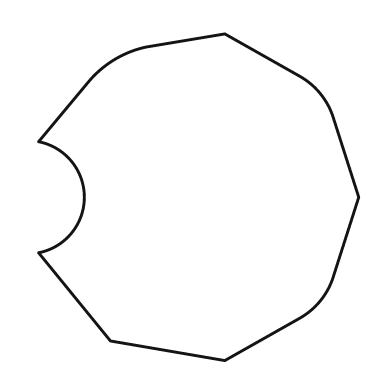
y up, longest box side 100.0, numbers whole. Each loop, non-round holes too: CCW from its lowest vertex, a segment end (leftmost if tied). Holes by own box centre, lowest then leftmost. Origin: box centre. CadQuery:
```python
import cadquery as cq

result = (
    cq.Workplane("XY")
    .moveTo(8.0, -50.0)
    .lineTo(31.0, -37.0)
    .threePointArc((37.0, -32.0), (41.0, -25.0))
    .lineTo(49.0, 0.0)
    .lineTo(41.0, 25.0)
    .threePointArc((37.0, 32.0), (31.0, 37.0))
    .lineTo(8.0, 50.0)
    .lineTo(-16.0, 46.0)
    .threePointArc((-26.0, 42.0), (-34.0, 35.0))
    .lineTo(-49.0, 17.0)
    .threePointArc((-35.0, 0.0), (-49.0, -17.0))
    .lineTo(-27.0, -44.0)
    .close()
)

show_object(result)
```